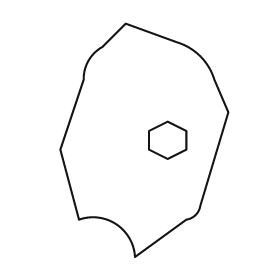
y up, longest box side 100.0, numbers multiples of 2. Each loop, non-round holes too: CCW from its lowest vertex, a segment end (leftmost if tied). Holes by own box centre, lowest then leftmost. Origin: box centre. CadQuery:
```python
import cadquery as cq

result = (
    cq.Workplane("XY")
    .moveTo(-4.0, -50.0)
    .lineTo(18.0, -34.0)
    .threePointArc((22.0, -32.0), (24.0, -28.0))
    .lineTo(36.0, 12.0)
    .lineTo(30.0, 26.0)
    .threePointArc((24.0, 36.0), (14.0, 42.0))
    .lineTo(-8.0, 50.0)
    .lineTo(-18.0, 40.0)
    .threePointArc((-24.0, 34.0), (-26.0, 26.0))
    .lineTo(-36.0, -4.0)
    .lineTo(-28.0, -34.0)
    .threePointArc((-12.0, -36.0), (-4.0, -50.0))
    .close()
    .moveTo(10.0, -8.0)
    .lineTo(18.0, -4.0)
    .lineTo(18.0, 4.0)
    .lineTo(10.0, 8.0)
    .lineTo(2.0, 4.0)
    .lineTo(2.0, -4.0)
    .close()
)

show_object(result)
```